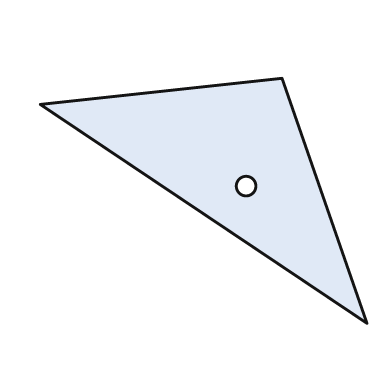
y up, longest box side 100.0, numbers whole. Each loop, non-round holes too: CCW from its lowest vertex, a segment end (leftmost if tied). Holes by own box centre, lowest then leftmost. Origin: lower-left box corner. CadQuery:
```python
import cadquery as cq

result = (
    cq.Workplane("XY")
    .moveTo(100.0, 0.0)
    .lineTo(74.0, 75.0)
    .lineTo(0.0, 67.0)
    .close()
    .moveTo(63.0, 42.0)
    .circle(3.0)
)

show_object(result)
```